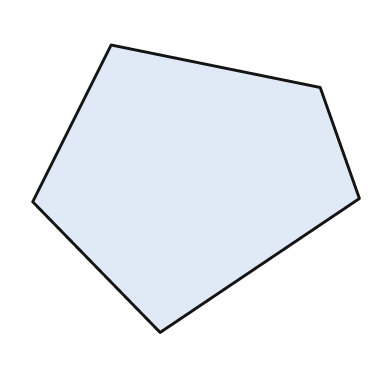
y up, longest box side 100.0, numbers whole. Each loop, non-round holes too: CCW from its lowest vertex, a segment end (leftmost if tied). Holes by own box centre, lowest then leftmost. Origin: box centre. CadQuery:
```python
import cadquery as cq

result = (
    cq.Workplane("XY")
    .moveTo(-11.0, -44.0)
    .lineTo(50.0, -3.0)
    .lineTo(38.0, 31.0)
    .lineTo(-26.0, 44.0)
    .lineTo(-50.0, -4.0)
    .close()
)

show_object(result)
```